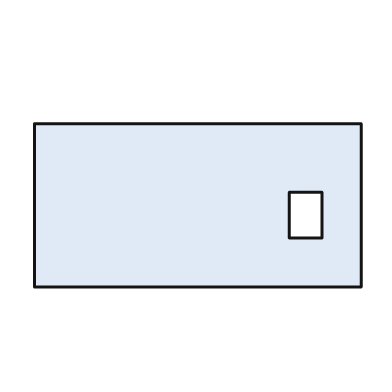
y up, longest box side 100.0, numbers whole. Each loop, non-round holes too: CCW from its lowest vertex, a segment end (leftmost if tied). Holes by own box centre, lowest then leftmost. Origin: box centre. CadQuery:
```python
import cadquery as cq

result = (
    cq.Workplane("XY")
    .moveTo(-50.0, -25.0)
    .lineTo(50.0, -25.0)
    .lineTo(50.0, 25.0)
    .lineTo(-50.0, 25.0)
    .close()
    .moveTo(28.0, -10.0)
    .lineTo(38.0, -10.0)
    .lineTo(38.0, 4.0)
    .lineTo(28.0, 4.0)
    .close()
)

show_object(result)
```